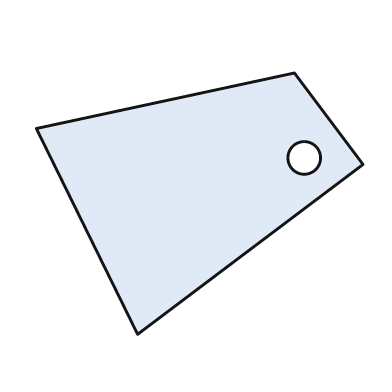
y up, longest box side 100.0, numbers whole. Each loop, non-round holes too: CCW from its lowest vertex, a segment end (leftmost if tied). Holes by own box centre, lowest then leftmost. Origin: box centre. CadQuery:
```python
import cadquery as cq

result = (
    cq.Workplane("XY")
    .moveTo(-19.0, -40.0)
    .lineTo(50.0, 12.0)
    .lineTo(29.0, 40.0)
    .lineTo(-50.0, 23.0)
    .close()
    .moveTo(32.0, 14.0)
    .circle(5.0)
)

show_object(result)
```